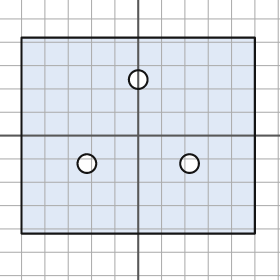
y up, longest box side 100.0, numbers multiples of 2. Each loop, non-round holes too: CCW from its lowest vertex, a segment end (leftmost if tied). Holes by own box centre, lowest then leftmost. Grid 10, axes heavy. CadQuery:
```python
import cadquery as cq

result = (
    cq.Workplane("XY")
    .moveTo(-50.0, -42.0)
    .lineTo(50.0, -42.0)
    .lineTo(50.0, 42.0)
    .lineTo(-50.0, 42.0)
    .close()
    .moveTo(-22.0, -12.0)
    .circle(4.0)
    .moveTo(22.0, -12.0)
    .circle(4.0)
    .moveTo(0.0, 24.0)
    .circle(4.0)
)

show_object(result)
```